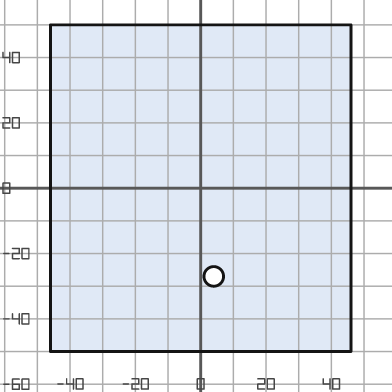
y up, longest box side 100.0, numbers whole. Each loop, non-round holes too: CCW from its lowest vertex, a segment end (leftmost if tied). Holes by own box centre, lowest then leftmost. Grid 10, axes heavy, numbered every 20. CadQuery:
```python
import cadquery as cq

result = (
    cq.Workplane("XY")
    .moveTo(-46.0, -50.0)
    .lineTo(46.0, -50.0)
    .lineTo(46.0, 50.0)
    .lineTo(-46.0, 50.0)
    .close()
    .moveTo(4.0, -27.0)
    .circle(3.0)
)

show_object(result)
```